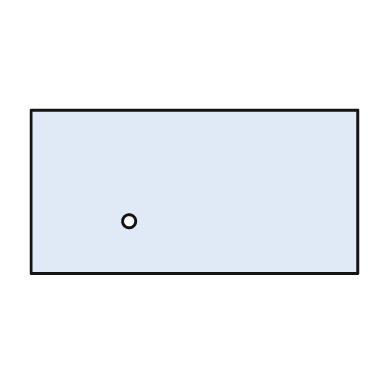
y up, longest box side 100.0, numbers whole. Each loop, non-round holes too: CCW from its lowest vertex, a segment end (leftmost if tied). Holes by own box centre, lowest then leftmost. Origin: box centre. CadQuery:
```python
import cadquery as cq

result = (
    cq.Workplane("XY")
    .moveTo(-50.0, -25.0)
    .lineTo(50.0, -25.0)
    .lineTo(50.0, 25.0)
    .lineTo(-50.0, 25.0)
    .close()
    .moveTo(-20.0, -9.0)
    .circle(2.0)
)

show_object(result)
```